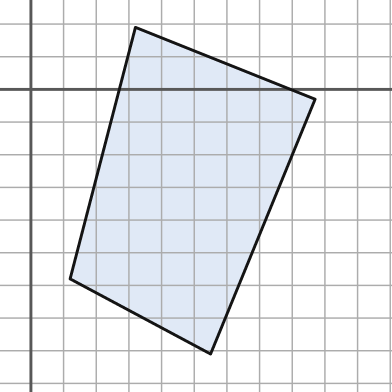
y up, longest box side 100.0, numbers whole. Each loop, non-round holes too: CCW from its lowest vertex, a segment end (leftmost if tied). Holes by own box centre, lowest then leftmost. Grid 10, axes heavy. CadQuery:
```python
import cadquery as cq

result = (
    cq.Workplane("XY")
    .moveTo(55.0, -81.0)
    .lineTo(87.0, -3.0)
    .lineTo(32.0, 19.0)
    .lineTo(12.0, -58.0)
    .close()
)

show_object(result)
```